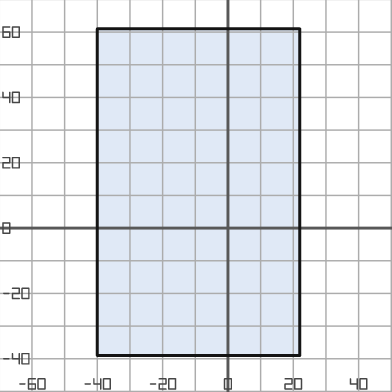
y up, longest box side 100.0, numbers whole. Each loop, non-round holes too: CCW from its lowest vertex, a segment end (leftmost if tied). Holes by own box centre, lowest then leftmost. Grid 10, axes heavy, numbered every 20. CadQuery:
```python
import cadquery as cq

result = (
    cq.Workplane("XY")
    .moveTo(-40.0, -39.0)
    .lineTo(22.0, -39.0)
    .lineTo(22.0, 61.0)
    .lineTo(-40.0, 61.0)
    .close()
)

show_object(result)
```